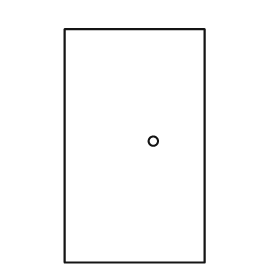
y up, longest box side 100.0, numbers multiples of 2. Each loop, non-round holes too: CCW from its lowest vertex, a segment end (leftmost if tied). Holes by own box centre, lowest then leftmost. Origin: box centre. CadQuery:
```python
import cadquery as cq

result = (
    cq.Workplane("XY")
    .moveTo(-30.0, -50.0)
    .lineTo(30.0, -50.0)
    .lineTo(30.0, 50.0)
    .lineTo(-30.0, 50.0)
    .close()
    .moveTo(8.0, 2.0)
    .circle(2.0)
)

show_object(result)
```